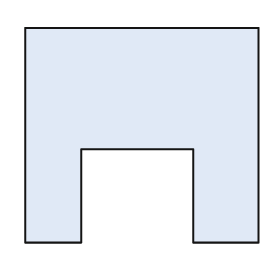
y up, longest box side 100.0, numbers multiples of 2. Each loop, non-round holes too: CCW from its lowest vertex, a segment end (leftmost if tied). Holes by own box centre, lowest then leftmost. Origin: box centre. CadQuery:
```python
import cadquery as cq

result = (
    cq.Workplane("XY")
    .moveTo(-50.0, -46.0)
    .lineTo(-26.0, -46.0)
    .lineTo(-26.0, -6.0)
    .lineTo(22.0, -6.0)
    .lineTo(22.0, -46.0)
    .lineTo(50.0, -46.0)
    .lineTo(50.0, 46.0)
    .lineTo(-50.0, 46.0)
    .close()
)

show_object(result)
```